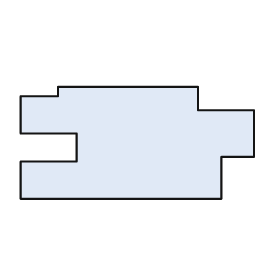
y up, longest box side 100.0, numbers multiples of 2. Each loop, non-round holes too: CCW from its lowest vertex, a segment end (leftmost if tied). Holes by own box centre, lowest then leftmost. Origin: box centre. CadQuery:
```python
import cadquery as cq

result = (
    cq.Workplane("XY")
    .moveTo(-50.0, -24.0)
    .lineTo(36.0, -24.0)
    .lineTo(36.0, -6.0)
    .lineTo(50.0, -6.0)
    .lineTo(50.0, 14.0)
    .lineTo(26.0, 14.0)
    .lineTo(26.0, 24.0)
    .lineTo(-34.0, 24.0)
    .lineTo(-34.0, 20.0)
    .lineTo(-50.0, 20.0)
    .lineTo(-50.0, 4.0)
    .lineTo(-26.0, 4.0)
    .lineTo(-26.0, -8.0)
    .lineTo(-50.0, -8.0)
    .close()
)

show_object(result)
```